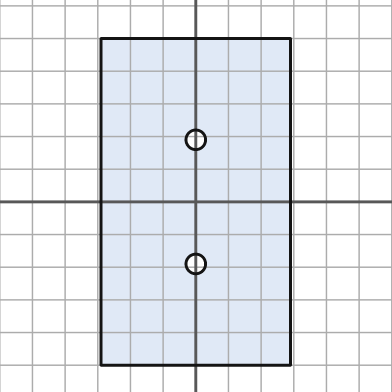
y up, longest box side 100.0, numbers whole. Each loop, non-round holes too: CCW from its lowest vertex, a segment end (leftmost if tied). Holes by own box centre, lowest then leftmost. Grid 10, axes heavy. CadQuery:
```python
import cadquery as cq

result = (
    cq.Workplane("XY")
    .moveTo(-29.0, -50.0)
    .lineTo(29.0, -50.0)
    .lineTo(29.0, 50.0)
    .lineTo(-29.0, 50.0)
    .close()
    .moveTo(0.0, -19.0)
    .circle(3.0)
    .moveTo(0.0, 19.0)
    .circle(3.0)
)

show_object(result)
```